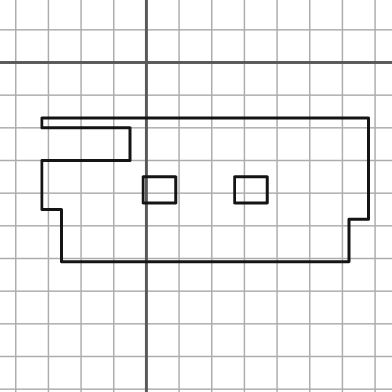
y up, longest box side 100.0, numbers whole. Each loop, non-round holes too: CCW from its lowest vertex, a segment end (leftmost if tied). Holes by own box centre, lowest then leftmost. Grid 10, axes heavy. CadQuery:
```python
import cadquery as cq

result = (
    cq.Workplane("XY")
    .moveTo(-26.0, -61.0)
    .lineTo(62.0, -61.0)
    .lineTo(62.0, -48.0)
    .lineTo(68.0, -48.0)
    .lineTo(68.0, -17.0)
    .lineTo(-32.0, -17.0)
    .lineTo(-32.0, -20.0)
    .lineTo(-5.0, -20.0)
    .lineTo(-5.0, -30.0)
    .lineTo(-32.0, -30.0)
    .lineTo(-32.0, -45.0)
    .lineTo(-26.0, -45.0)
    .close()
    .moveTo(-1.0, -43.0)
    .lineTo(9.0, -43.0)
    .lineTo(9.0, -35.0)
    .lineTo(-1.0, -35.0)
    .close()
    .moveTo(27.0, -43.0)
    .lineTo(37.0, -43.0)
    .lineTo(37.0, -35.0)
    .lineTo(27.0, -35.0)
    .close()
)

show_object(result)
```